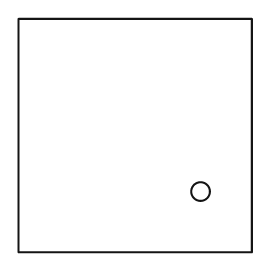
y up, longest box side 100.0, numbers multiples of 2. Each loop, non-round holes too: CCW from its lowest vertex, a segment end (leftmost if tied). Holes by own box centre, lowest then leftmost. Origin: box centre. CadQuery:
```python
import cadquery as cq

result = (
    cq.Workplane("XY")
    .moveTo(-50.0, -50.0)
    .lineTo(50.0, -50.0)
    .lineTo(50.0, 50.0)
    .lineTo(-50.0, 50.0)
    .close()
    .moveTo(28.0, -24.0)
    .circle(4.0)
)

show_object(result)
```